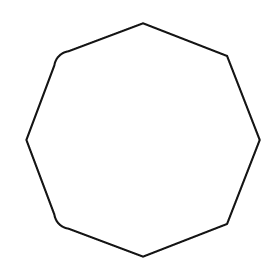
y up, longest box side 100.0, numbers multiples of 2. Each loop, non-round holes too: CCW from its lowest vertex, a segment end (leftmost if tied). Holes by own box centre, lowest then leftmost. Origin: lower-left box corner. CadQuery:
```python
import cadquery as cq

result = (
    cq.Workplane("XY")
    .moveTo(50.0, 0.0)
    .lineTo(86.0, 14.0)
    .lineTo(100.0, 50.0)
    .lineTo(86.0, 86.0)
    .lineTo(50.0, 100.0)
    .lineTo(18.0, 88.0)
    .threePointArc((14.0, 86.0), (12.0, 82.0))
    .lineTo(0.0, 50.0)
    .lineTo(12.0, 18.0)
    .threePointArc((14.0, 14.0), (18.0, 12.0))
    .close()
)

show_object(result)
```